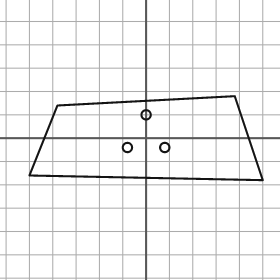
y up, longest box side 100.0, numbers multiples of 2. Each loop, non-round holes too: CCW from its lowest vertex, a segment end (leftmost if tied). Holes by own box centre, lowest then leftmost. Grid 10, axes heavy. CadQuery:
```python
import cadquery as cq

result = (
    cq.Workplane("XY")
    .moveTo(50.0, -18.0)
    .lineTo(38.0, 18.0)
    .lineTo(-38.0, 14.0)
    .lineTo(-50.0, -16.0)
    .close()
    .moveTo(-8.0, -4.0)
    .circle(2.0)
    .moveTo(8.0, -4.0)
    .circle(2.0)
    .moveTo(0.0, 10.0)
    .circle(2.0)
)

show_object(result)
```